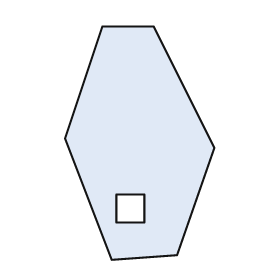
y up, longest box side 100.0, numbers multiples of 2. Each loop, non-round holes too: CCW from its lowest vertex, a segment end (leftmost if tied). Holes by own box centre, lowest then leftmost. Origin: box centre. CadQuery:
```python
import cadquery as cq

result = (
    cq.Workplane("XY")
    .moveTo(-12.0, -50.0)
    .lineTo(16.0, -48.0)
    .lineTo(32.0, -2.0)
    .lineTo(6.0, 50.0)
    .lineTo(-16.0, 50.0)
    .lineTo(-32.0, 2.0)
    .close()
    .moveTo(-10.0, -34.0)
    .lineTo(2.0, -34.0)
    .lineTo(2.0, -22.0)
    .lineTo(-10.0, -22.0)
    .close()
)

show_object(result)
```